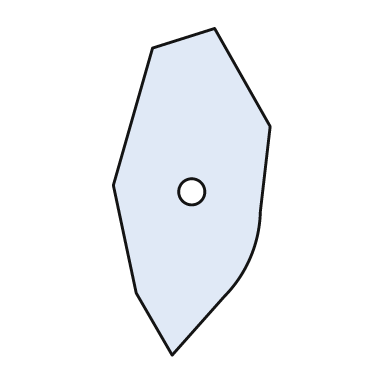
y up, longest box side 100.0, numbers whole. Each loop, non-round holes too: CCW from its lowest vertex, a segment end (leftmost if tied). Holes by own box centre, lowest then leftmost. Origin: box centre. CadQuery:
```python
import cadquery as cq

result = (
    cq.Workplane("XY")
    .moveTo(-6.0, -50.0)
    .lineTo(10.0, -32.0)
    .threePointArc((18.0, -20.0), (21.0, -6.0))
    .lineTo(24.0, 20.0)
    .lineTo(7.0, 50.0)
    .lineTo(-12.0, 44.0)
    .lineTo(-24.0, 2.0)
    .lineTo(-17.0, -31.0)
    .close()
    .moveTo(0.0, 0.0)
    .circle(4.0)
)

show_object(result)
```